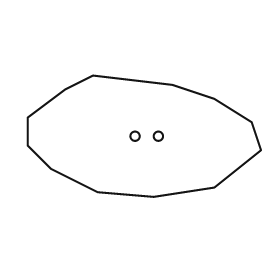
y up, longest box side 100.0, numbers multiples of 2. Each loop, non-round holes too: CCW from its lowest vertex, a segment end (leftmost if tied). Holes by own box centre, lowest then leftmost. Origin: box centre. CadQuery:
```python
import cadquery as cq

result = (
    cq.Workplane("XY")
    .moveTo(4.0, -26.0)
    .lineTo(30.0, -22.0)
    .lineTo(50.0, -6.0)
    .lineTo(46.0, 6.0)
    .lineTo(30.0, 16.0)
    .lineTo(12.0, 22.0)
    .lineTo(-22.0, 26.0)
    .lineTo(-34.0, 20.0)
    .lineTo(-50.0, 8.0)
    .lineTo(-50.0, -4.0)
    .lineTo(-40.0, -14.0)
    .lineTo(-20.0, -24.0)
    .close()
    .moveTo(-4.0, 0.0)
    .circle(2.0)
    .moveTo(6.0, 0.0)
    .circle(2.0)
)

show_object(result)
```